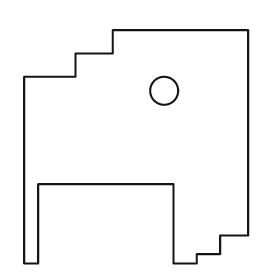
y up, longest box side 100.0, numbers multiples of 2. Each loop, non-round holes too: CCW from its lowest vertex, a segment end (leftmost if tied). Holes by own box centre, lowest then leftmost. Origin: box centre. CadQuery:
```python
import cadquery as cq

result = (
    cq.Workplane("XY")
    .moveTo(-48.0, -50.0)
    .lineTo(-42.0, -50.0)
    .lineTo(-42.0, -16.0)
    .lineTo(16.0, -16.0)
    .lineTo(16.0, -50.0)
    .lineTo(26.0, -50.0)
    .lineTo(26.0, -46.0)
    .lineTo(36.0, -46.0)
    .lineTo(36.0, -38.0)
    .lineTo(48.0, -38.0)
    .lineTo(48.0, 50.0)
    .lineTo(-10.0, 50.0)
    .lineTo(-10.0, 40.0)
    .lineTo(-26.0, 40.0)
    .lineTo(-26.0, 30.0)
    .lineTo(-48.0, 30.0)
    .close()
    .moveTo(12.0, 24.0)
    .circle(6.0)
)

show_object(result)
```